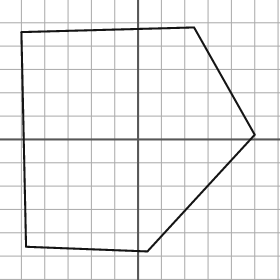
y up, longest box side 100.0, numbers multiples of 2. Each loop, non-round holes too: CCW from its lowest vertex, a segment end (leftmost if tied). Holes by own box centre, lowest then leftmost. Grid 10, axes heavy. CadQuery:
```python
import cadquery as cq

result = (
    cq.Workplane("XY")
    .moveTo(4.0, -48.0)
    .lineTo(50.0, 2.0)
    .lineTo(24.0, 48.0)
    .lineTo(-50.0, 46.0)
    .lineTo(-48.0, -46.0)
    .close()
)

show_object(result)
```